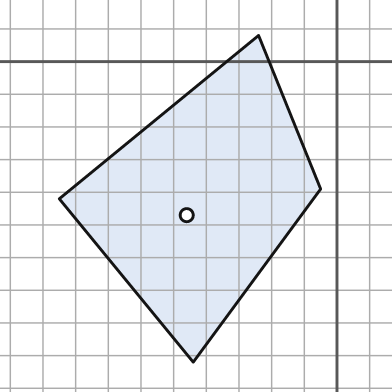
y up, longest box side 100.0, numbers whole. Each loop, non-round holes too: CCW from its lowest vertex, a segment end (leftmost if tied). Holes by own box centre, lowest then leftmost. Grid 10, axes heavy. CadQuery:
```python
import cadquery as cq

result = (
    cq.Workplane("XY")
    .moveTo(-44.0, -92.0)
    .lineTo(-5.0, -39.0)
    .lineTo(-24.0, 8.0)
    .lineTo(-85.0, -42.0)
    .close()
    .moveTo(-46.0, -47.0)
    .circle(2.0)
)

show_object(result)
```